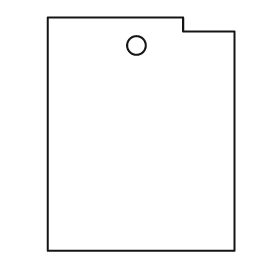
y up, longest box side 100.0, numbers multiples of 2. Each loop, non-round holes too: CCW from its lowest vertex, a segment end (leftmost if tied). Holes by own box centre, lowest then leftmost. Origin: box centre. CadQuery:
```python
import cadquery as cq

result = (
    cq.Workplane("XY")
    .moveTo(-40.0, -50.0)
    .lineTo(40.0, -50.0)
    .lineTo(40.0, 44.0)
    .lineTo(18.0, 44.0)
    .lineTo(18.0, 50.0)
    .lineTo(-40.0, 50.0)
    .close()
    .moveTo(-2.0, 38.0)
    .circle(4.0)
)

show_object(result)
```